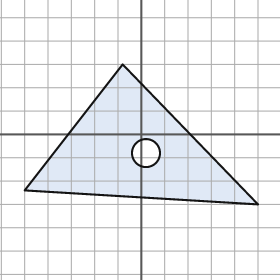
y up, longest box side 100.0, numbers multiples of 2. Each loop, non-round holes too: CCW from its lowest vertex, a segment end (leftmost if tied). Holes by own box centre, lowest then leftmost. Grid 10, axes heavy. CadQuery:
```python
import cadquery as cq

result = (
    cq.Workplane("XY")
    .moveTo(50.0, -30.0)
    .lineTo(-8.0, 30.0)
    .lineTo(-50.0, -24.0)
    .close()
    .moveTo(2.0, -8.0)
    .circle(6.0)
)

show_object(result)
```